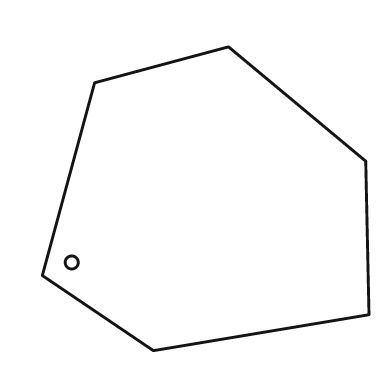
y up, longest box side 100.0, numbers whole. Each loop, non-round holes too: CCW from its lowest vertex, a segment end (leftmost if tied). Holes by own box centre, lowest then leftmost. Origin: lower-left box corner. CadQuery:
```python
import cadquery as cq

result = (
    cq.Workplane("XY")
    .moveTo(34.0, 0.0)
    .lineTo(100.0, 11.0)
    .lineTo(99.0, 58.0)
    .lineTo(57.0, 93.0)
    .lineTo(16.0, 82.0)
    .lineTo(0.0, 23.0)
    .close()
    .moveTo(9.0, 27.0)
    .circle(2.0)
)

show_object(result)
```